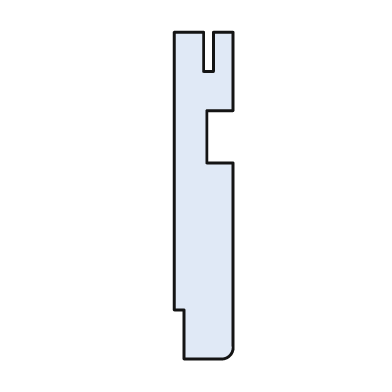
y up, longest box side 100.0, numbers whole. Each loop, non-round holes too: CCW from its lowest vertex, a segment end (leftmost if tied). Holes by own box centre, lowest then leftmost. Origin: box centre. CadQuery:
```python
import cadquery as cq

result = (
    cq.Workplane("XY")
    .moveTo(-6.0, -50.0)
    .lineTo(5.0, -50.0)
    .threePointArc((8.0, -49.0), (9.0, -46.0))
    .lineTo(9.0, 10.0)
    .lineTo(1.0, 10.0)
    .lineTo(1.0, 26.0)
    .lineTo(9.0, 26.0)
    .lineTo(9.0, 50.0)
    .lineTo(3.0, 50.0)
    .lineTo(3.0, 38.0)
    .lineTo(0.0, 38.0)
    .lineTo(0.0, 50.0)
    .lineTo(-9.0, 50.0)
    .lineTo(-9.0, -35.0)
    .lineTo(-6.0, -35.0)
    .close()
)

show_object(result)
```